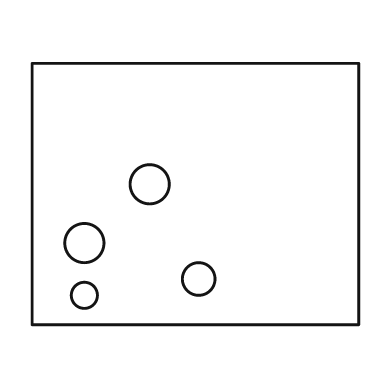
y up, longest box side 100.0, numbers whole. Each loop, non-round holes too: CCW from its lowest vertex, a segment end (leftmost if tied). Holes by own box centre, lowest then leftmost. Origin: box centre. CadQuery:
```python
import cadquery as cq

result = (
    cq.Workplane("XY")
    .moveTo(-50.0, -40.0)
    .lineTo(50.0, -40.0)
    .lineTo(50.0, 40.0)
    .lineTo(-50.0, 40.0)
    .close()
    .moveTo(-34.0, -31.0)
    .circle(4.0)
    .moveTo(1.0, -26.0)
    .circle(5.0)
    .moveTo(-34.0, -15.0)
    .circle(6.0)
    .moveTo(-14.0, 3.0)
    .circle(6.0)
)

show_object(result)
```